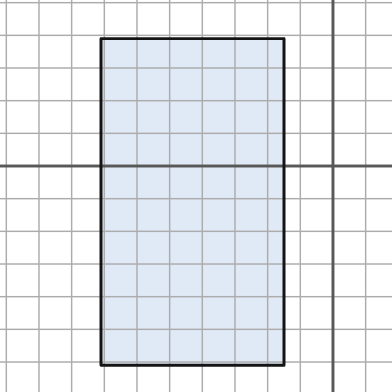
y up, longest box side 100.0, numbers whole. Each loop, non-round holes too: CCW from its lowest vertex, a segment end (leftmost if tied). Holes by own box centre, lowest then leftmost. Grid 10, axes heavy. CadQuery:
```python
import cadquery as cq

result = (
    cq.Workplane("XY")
    .moveTo(-71.0, -61.0)
    .lineTo(-15.0, -61.0)
    .lineTo(-15.0, 39.0)
    .lineTo(-71.0, 39.0)
    .close()
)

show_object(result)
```